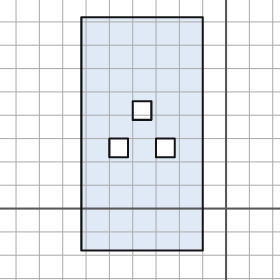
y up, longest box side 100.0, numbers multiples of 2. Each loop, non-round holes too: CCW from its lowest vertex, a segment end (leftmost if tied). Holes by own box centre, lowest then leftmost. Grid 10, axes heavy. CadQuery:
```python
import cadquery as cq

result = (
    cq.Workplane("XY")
    .moveTo(-62.0, -18.0)
    .lineTo(-10.0, -18.0)
    .lineTo(-10.0, 82.0)
    .lineTo(-62.0, 82.0)
    .close()
    .moveTo(-50.0, 22.0)
    .lineTo(-42.0, 22.0)
    .lineTo(-42.0, 30.0)
    .lineTo(-50.0, 30.0)
    .close()
    .moveTo(-30.0, 22.0)
    .lineTo(-22.0, 22.0)
    .lineTo(-22.0, 30.0)
    .lineTo(-30.0, 30.0)
    .close()
    .moveTo(-40.0, 38.0)
    .lineTo(-32.0, 38.0)
    .lineTo(-32.0, 46.0)
    .lineTo(-40.0, 46.0)
    .close()
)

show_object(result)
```